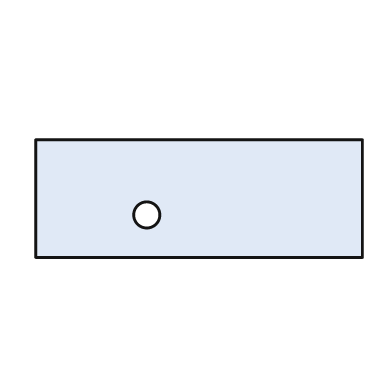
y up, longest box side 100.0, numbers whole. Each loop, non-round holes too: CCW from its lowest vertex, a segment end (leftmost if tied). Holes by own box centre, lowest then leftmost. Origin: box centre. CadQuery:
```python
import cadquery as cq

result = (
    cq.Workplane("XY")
    .moveTo(-50.0, -18.0)
    .lineTo(50.0, -18.0)
    .lineTo(50.0, 18.0)
    .lineTo(-50.0, 18.0)
    .close()
    .moveTo(-16.0, -5.0)
    .circle(4.0)
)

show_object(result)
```